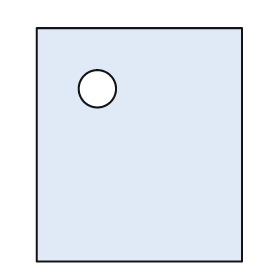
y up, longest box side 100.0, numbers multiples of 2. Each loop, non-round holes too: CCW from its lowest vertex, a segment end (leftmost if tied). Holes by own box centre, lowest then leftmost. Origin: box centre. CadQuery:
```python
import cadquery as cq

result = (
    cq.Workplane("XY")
    .moveTo(-44.0, -50.0)
    .lineTo(44.0, -50.0)
    .lineTo(44.0, 50.0)
    .lineTo(-44.0, 50.0)
    .close()
    .moveTo(-18.0, 24.0)
    .circle(8.0)
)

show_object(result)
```